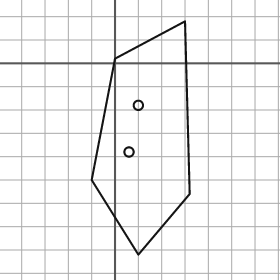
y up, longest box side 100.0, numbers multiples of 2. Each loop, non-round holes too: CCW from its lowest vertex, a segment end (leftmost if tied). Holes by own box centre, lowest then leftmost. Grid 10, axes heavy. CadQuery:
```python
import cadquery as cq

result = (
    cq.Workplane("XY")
    .moveTo(10.0, -82.0)
    .lineTo(32.0, -56.0)
    .lineTo(30.0, 18.0)
    .lineTo(0.0, 2.0)
    .lineTo(-10.0, -50.0)
    .close()
    .moveTo(6.0, -38.0)
    .circle(2.0)
    .moveTo(10.0, -18.0)
    .circle(2.0)
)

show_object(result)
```